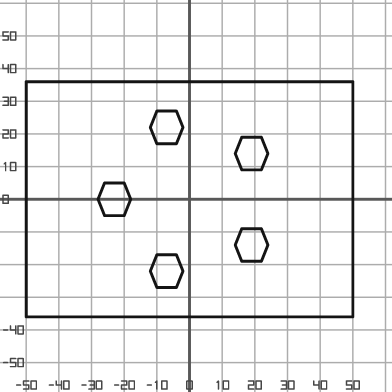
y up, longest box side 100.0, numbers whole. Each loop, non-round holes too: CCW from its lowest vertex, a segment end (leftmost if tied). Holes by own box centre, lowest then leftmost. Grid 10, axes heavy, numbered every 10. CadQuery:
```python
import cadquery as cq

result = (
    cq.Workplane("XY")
    .moveTo(-50.0, -36.0)
    .lineTo(50.0, -36.0)
    .lineTo(50.0, 36.0)
    .lineTo(-50.0, 36.0)
    .close()
    .moveTo(-10.0, -27.0)
    .lineTo(-4.0, -27.0)
    .lineTo(-2.0, -22.0)
    .lineTo(-4.0, -17.0)
    .lineTo(-10.0, -17.0)
    .lineTo(-12.0, -22.0)
    .close()
    .moveTo(16.0, -19.0)
    .lineTo(22.0, -19.0)
    .lineTo(24.0, -14.0)
    .lineTo(22.0, -9.0)
    .lineTo(16.0, -9.0)
    .lineTo(14.0, -14.0)
    .close()
    .moveTo(-26.0, -5.0)
    .lineTo(-20.0, -5.0)
    .lineTo(-18.0, 0.0)
    .lineTo(-20.0, 5.0)
    .lineTo(-26.0, 5.0)
    .lineTo(-28.0, 0.0)
    .close()
    .moveTo(16.0, 9.0)
    .lineTo(22.0, 9.0)
    .lineTo(24.0, 14.0)
    .lineTo(22.0, 19.0)
    .lineTo(16.0, 19.0)
    .lineTo(14.0, 14.0)
    .close()
    .moveTo(-10.0, 17.0)
    .lineTo(-4.0, 17.0)
    .lineTo(-2.0, 22.0)
    .lineTo(-4.0, 27.0)
    .lineTo(-10.0, 27.0)
    .lineTo(-12.0, 22.0)
    .close()
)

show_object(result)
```